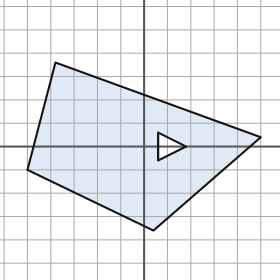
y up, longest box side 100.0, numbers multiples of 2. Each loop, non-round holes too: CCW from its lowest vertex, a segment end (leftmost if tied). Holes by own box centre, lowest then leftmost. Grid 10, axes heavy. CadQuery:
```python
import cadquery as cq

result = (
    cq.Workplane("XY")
    .moveTo(4.0, -36.0)
    .lineTo(50.0, 4.0)
    .lineTo(-38.0, 36.0)
    .lineTo(-50.0, -10.0)
    .close()
    .moveTo(6.0, -6.0)
    .lineTo(18.0, 0.0)
    .lineTo(6.0, 6.0)
    .close()
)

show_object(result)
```